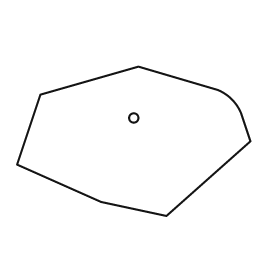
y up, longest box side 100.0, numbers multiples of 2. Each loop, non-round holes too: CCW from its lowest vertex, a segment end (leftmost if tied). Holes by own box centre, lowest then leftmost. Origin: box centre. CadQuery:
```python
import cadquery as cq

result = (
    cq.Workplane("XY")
    .moveTo(14.0, -32.0)
    .lineTo(50.0, 0.0)
    .lineTo(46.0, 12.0)
    .threePointArc((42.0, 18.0), (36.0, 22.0))
    .lineTo(2.0, 32.0)
    .lineTo(-40.0, 20.0)
    .lineTo(-50.0, -10.0)
    .lineTo(-14.0, -26.0)
    .close()
    .moveTo(0.0, 10.0)
    .circle(2.0)
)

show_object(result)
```